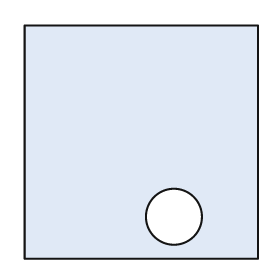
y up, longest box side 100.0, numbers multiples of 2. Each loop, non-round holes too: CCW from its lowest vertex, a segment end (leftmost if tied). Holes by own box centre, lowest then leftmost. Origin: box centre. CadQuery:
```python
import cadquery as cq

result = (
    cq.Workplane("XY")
    .moveTo(-50.0, -50.0)
    .lineTo(50.0, -50.0)
    .lineTo(50.0, 50.0)
    .lineTo(-50.0, 50.0)
    .close()
    .moveTo(14.0, -32.0)
    .circle(12.0)
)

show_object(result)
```